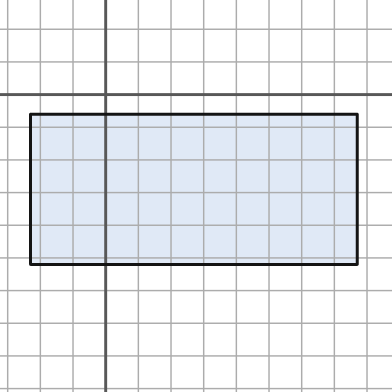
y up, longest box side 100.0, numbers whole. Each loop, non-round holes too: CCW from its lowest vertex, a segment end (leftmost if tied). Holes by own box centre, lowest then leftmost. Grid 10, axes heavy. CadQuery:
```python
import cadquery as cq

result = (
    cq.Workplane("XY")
    .moveTo(-23.0, -52.0)
    .lineTo(77.0, -52.0)
    .lineTo(77.0, -6.0)
    .lineTo(-23.0, -6.0)
    .close()
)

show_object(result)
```